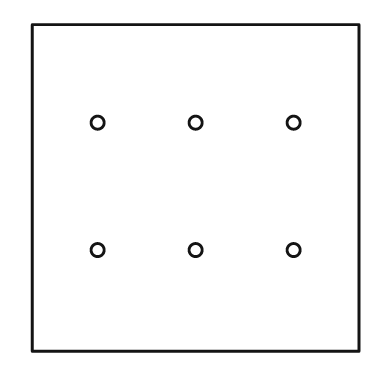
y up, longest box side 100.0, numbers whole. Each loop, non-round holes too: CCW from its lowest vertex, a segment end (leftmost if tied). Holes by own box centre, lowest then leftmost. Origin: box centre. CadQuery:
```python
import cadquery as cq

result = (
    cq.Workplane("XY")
    .moveTo(-50.0, -50.0)
    .lineTo(50.0, -50.0)
    .lineTo(50.0, 50.0)
    .lineTo(-50.0, 50.0)
    .close()
    .moveTo(-30.0, -19.0)
    .circle(2.0)
    .moveTo(0.0, -19.0)
    .circle(2.0)
    .moveTo(30.0, -19.0)
    .circle(2.0)
    .moveTo(-30.0, 20.0)
    .circle(2.0)
    .moveTo(0.0, 20.0)
    .circle(2.0)
    .moveTo(30.0, 20.0)
    .circle(2.0)
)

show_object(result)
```